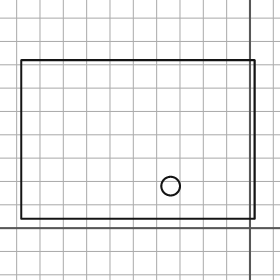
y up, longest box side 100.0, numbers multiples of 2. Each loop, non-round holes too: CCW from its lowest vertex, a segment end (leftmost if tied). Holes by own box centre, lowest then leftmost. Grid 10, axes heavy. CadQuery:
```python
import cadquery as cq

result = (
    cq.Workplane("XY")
    .moveTo(-98.0, 4.0)
    .lineTo(2.0, 4.0)
    .lineTo(2.0, 72.0)
    .lineTo(-98.0, 72.0)
    .close()
    .moveTo(-34.0, 18.0)
    .circle(4.0)
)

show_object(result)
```